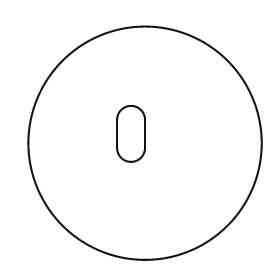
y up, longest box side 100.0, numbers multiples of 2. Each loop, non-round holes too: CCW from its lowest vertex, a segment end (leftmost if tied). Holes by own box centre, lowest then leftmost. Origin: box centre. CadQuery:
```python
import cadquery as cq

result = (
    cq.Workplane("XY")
    .moveTo(0.0, 0.0)
    .circle(50.0)
    .moveTo(-12.0, -2.0)
    .threePointArc((-6.0, -8.0), (0.0, -2.0))
    .lineTo(0.0, 10.0)
    .threePointArc((-6.0, 16.0), (-12.0, 10.0))
    .close()
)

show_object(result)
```